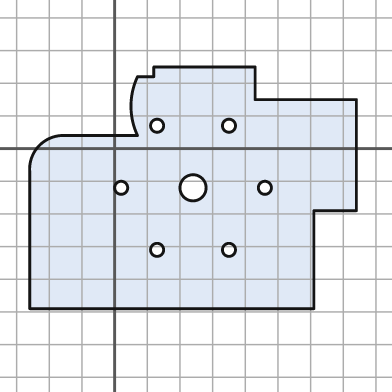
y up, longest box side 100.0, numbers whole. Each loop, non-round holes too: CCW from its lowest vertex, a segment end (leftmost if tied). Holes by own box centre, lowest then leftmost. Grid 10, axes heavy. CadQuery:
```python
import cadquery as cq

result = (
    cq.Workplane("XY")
    .moveTo(-26.0, -49.0)
    .lineTo(61.0, -49.0)
    .lineTo(61.0, -19.0)
    .lineTo(74.0, -19.0)
    .lineTo(74.0, 15.0)
    .lineTo(43.0, 15.0)
    .lineTo(43.0, 25.0)
    .lineTo(12.0, 25.0)
    .lineTo(12.0, 22.0)
    .lineTo(7.0, 22.0)
    .threePointArc((5.0, 13.0), (7.0, 4.0))
    .lineTo(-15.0, 4.0)
    .threePointArc((-23.0, 1.0), (-26.0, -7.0))
    .close()
    .moveTo(13.0, -31.0)
    .circle(2.0)
    .moveTo(35.0, -31.0)
    .circle(2.0)
    .moveTo(2.0, -12.0)
    .circle(2.0)
    .moveTo(24.0, -12.0)
    .circle(4.0)
    .moveTo(46.0, -12.0)
    .circle(2.0)
    .moveTo(13.0, 7.0)
    .circle(2.0)
    .moveTo(35.0, 7.0)
    .circle(2.0)
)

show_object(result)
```